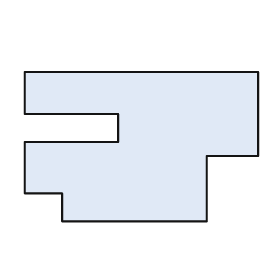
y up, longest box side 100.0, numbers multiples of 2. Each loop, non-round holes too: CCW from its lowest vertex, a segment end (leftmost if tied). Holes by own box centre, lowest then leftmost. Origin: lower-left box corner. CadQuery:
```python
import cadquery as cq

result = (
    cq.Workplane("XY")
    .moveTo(16.0, 0.0)
    .lineTo(78.0, 0.0)
    .lineTo(78.0, 28.0)
    .lineTo(100.0, 28.0)
    .lineTo(100.0, 64.0)
    .lineTo(0.0, 64.0)
    .lineTo(0.0, 46.0)
    .lineTo(40.0, 46.0)
    .lineTo(40.0, 34.0)
    .lineTo(0.0, 34.0)
    .lineTo(0.0, 12.0)
    .lineTo(16.0, 12.0)
    .close()
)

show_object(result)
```